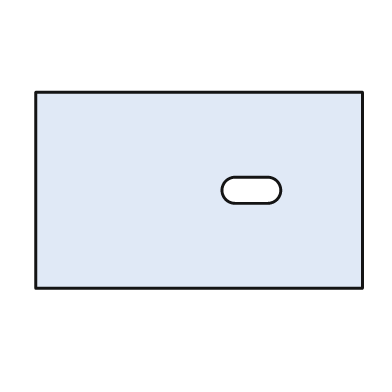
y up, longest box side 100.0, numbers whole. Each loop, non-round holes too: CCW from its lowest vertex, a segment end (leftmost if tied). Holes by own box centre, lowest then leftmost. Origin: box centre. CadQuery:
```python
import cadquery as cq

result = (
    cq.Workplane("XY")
    .moveTo(-50.0, -30.0)
    .lineTo(50.0, -30.0)
    .lineTo(50.0, 30.0)
    .lineTo(-50.0, 30.0)
    .close()
    .moveTo(11.0, -4.0)
    .lineTo(21.0, -4.0)
    .threePointArc((25.0, 0.0), (21.0, 4.0))
    .lineTo(11.0, 4.0)
    .threePointArc((7.0, 0.0), (11.0, -4.0))
    .close()
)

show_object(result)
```